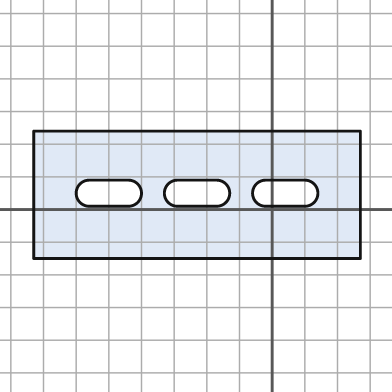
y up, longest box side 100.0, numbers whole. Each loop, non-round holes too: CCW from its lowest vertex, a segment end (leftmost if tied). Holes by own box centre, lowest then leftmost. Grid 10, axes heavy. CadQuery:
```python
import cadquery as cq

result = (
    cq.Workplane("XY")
    .moveTo(-73.0, -15.0)
    .lineTo(27.0, -15.0)
    .lineTo(27.0, 24.0)
    .lineTo(-73.0, 24.0)
    .close()
    .moveTo(-56.0, 1.0)
    .lineTo(-44.0, 1.0)
    .threePointArc((-40.0, 5.0), (-44.0, 9.0))
    .lineTo(-56.0, 9.0)
    .threePointArc((-60.0, 5.0), (-56.0, 1.0))
    .close()
    .moveTo(-29.0, 1.0)
    .lineTo(-17.0, 1.0)
    .threePointArc((-13.0, 5.0), (-17.0, 9.0))
    .lineTo(-29.0, 9.0)
    .threePointArc((-33.0, 5.0), (-29.0, 1.0))
    .close()
    .moveTo(-2.0, 1.0)
    .lineTo(10.0, 1.0)
    .threePointArc((14.0, 5.0), (10.0, 9.0))
    .lineTo(-2.0, 9.0)
    .threePointArc((-6.0, 5.0), (-2.0, 1.0))
    .close()
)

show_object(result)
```